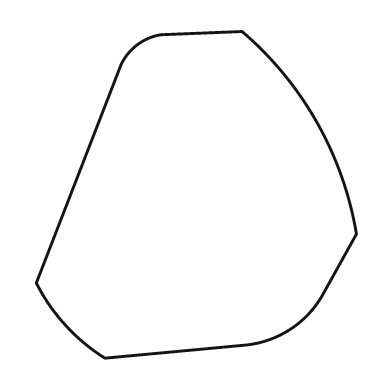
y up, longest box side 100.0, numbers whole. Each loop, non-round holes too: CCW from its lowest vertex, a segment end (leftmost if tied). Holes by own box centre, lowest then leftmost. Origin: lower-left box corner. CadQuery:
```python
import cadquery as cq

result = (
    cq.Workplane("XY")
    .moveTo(21.0, 0.0)
    .lineTo(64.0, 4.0)
    .threePointArc((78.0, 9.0), (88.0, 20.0))
    .lineTo(98.0, 38.0)
    .threePointArc((86.0, 72.0), (63.0, 100.0))
    .lineTo(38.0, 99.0)
    .threePointArc((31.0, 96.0), (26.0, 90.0))
    .lineTo(0.0, 23.0)
    .threePointArc((9.0, 10.0), (21.0, 0.0))
    .close()
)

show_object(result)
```